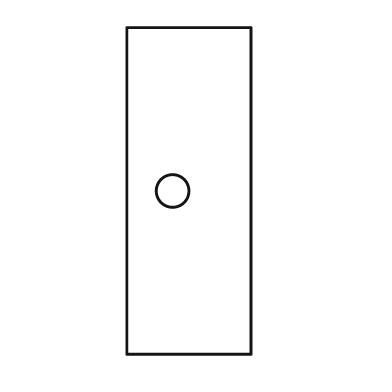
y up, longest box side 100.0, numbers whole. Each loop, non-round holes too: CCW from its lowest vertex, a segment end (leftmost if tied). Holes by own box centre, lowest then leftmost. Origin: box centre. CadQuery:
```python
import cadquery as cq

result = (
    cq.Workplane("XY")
    .moveTo(-19.0, -50.0)
    .lineTo(19.0, -50.0)
    .lineTo(19.0, 50.0)
    .lineTo(-19.0, 50.0)
    .close()
    .moveTo(-5.0, 0.0)
    .circle(5.0)
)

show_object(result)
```